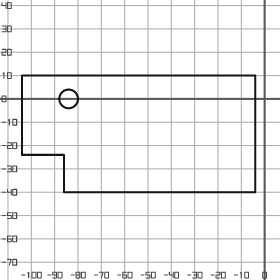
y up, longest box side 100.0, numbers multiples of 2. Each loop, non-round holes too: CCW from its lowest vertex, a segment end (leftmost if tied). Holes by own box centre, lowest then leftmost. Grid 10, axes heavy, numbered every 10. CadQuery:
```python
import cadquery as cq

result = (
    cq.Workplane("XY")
    .moveTo(-86.0, -40.0)
    .lineTo(-4.0, -40.0)
    .lineTo(-4.0, 10.0)
    .lineTo(-104.0, 10.0)
    .lineTo(-104.0, -24.0)
    .lineTo(-86.0, -24.0)
    .close()
    .moveTo(-84.0, 0.0)
    .circle(4.0)
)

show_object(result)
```